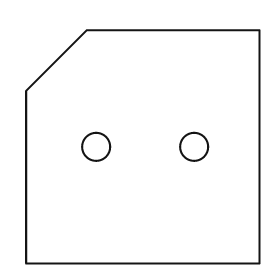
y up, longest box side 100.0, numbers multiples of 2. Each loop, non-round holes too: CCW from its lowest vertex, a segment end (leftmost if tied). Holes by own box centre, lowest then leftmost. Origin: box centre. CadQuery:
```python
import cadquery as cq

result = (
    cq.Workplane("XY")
    .moveTo(-50.0, -50.0)
    .lineTo(50.0, -50.0)
    .lineTo(50.0, 50.0)
    .lineTo(-24.0, 50.0)
    .lineTo(-50.0, 24.0)
    .close()
    .moveTo(-20.0, 0.0)
    .circle(6.0)
    .moveTo(22.0, 0.0)
    .circle(6.0)
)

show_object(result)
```